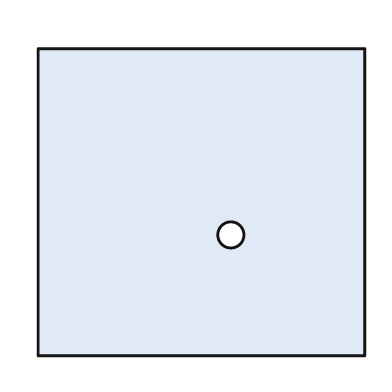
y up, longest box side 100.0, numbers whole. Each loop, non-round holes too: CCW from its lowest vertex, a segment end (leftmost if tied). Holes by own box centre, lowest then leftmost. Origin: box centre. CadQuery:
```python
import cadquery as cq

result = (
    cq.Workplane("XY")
    .moveTo(-50.0, -47.0)
    .lineTo(50.0, -47.0)
    .lineTo(50.0, 47.0)
    .lineTo(-50.0, 47.0)
    .close()
    .moveTo(9.0, -10.0)
    .circle(4.0)
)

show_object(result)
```